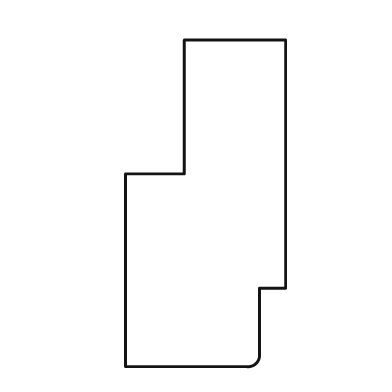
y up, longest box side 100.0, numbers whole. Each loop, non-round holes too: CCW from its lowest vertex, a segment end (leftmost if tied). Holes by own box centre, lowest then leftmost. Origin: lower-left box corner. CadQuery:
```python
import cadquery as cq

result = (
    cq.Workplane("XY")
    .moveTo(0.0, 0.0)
    .lineTo(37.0, 0.0)
    .threePointArc((40.0, 1.0), (41.0, 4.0))
    .lineTo(41.0, 24.0)
    .lineTo(49.0, 24.0)
    .lineTo(49.0, 100.0)
    .lineTo(18.0, 100.0)
    .lineTo(18.0, 59.0)
    .lineTo(0.0, 59.0)
    .close()
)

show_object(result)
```